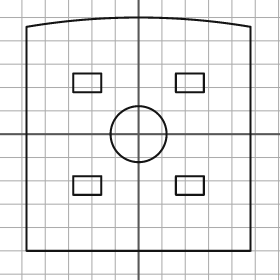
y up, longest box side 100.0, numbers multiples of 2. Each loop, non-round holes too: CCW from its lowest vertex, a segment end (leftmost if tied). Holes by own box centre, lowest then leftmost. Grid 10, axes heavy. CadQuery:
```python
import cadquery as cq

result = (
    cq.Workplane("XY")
    .moveTo(-48.0, -50.0)
    .lineTo(48.0, -50.0)
    .lineTo(48.0, 46.0)
    .threePointArc((0.0, 50.0), (-48.0, 46.0))
    .close()
    .moveTo(-28.0, -26.0)
    .lineTo(-16.0, -26.0)
    .lineTo(-16.0, -18.0)
    .lineTo(-28.0, -18.0)
    .close()
    .moveTo(16.0, -26.0)
    .lineTo(28.0, -26.0)
    .lineTo(28.0, -18.0)
    .lineTo(16.0, -18.0)
    .close()
    .moveTo(0.0, 0.0)
    .circle(12.0)
    .moveTo(-28.0, 18.0)
    .lineTo(-16.0, 18.0)
    .lineTo(-16.0, 26.0)
    .lineTo(-28.0, 26.0)
    .close()
    .moveTo(16.0, 18.0)
    .lineTo(28.0, 18.0)
    .lineTo(28.0, 26.0)
    .lineTo(16.0, 26.0)
    .close()
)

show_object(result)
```